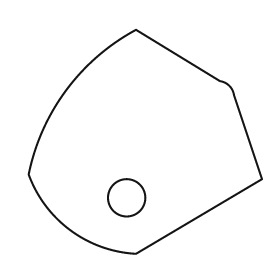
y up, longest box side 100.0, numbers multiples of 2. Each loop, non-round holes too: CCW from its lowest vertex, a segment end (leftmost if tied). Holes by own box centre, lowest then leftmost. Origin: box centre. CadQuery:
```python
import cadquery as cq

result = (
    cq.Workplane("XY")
    .moveTo(-4.0, -48.0)
    .lineTo(50.0, -16.0)
    .lineTo(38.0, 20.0)
    .threePointArc((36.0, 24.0), (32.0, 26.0))
    .lineTo(-4.0, 48.0)
    .threePointArc((-34.0, 22.0), (-50.0, -14.0))
    .threePointArc((-32.0, -38.0), (-4.0, -48.0))
    .close()
    .moveTo(-8.0, -24.0)
    .circle(8.0)
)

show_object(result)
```